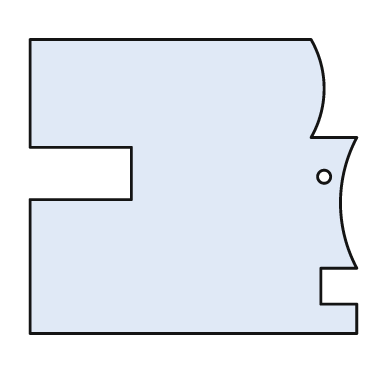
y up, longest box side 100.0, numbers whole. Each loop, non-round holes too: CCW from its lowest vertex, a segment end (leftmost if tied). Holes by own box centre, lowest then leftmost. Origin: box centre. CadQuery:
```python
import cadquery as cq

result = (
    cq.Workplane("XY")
    .moveTo(-50.0, -45.0)
    .lineTo(50.0, -45.0)
    .lineTo(50.0, -36.0)
    .lineTo(39.0, -36.0)
    .lineTo(39.0, -25.0)
    .lineTo(50.0, -25.0)
    .threePointArc((45.0, -5.0), (50.0, 15.0))
    .lineTo(36.0, 15.0)
    .threePointArc((40.0, 30.0), (36.0, 45.0))
    .lineTo(-50.0, 45.0)
    .lineTo(-50.0, 12.0)
    .lineTo(-19.0, 12.0)
    .lineTo(-19.0, -4.0)
    .lineTo(-50.0, -4.0)
    .close()
    .moveTo(40.0, 3.0)
    .circle(2.0)
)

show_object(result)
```